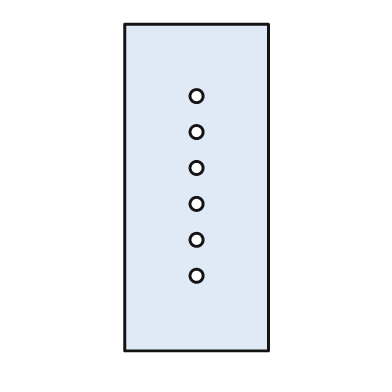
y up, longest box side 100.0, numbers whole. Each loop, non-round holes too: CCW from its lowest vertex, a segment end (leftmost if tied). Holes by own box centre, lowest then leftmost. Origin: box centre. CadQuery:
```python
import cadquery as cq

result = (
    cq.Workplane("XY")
    .moveTo(-22.0, -50.0)
    .lineTo(22.0, -50.0)
    .lineTo(22.0, 50.0)
    .lineTo(-22.0, 50.0)
    .close()
    .moveTo(0.0, -27.0)
    .circle(2.0)
    .moveTo(0.0, -16.0)
    .circle(2.0)
    .moveTo(0.0, -5.0)
    .circle(2.0)
    .moveTo(0.0, 6.0)
    .circle(2.0)
    .moveTo(0.0, 17.0)
    .circle(2.0)
    .moveTo(0.0, 28.0)
    .circle(2.0)
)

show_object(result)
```